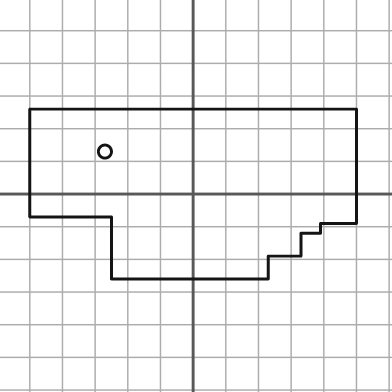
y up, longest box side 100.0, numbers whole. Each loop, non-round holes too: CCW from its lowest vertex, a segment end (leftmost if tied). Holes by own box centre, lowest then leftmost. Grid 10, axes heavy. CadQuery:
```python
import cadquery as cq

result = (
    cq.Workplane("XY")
    .moveTo(-25.0, -26.0)
    .lineTo(23.0, -26.0)
    .lineTo(23.0, -19.0)
    .lineTo(33.0, -19.0)
    .lineTo(33.0, -12.0)
    .lineTo(39.0, -12.0)
    .lineTo(39.0, -9.0)
    .lineTo(50.0, -9.0)
    .lineTo(50.0, 26.0)
    .lineTo(-50.0, 26.0)
    .lineTo(-50.0, -7.0)
    .lineTo(-25.0, -7.0)
    .close()
    .moveTo(-27.0, 13.0)
    .circle(2.0)
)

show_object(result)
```